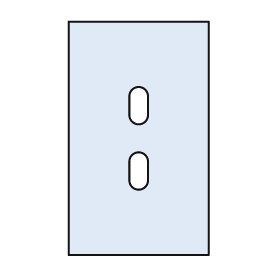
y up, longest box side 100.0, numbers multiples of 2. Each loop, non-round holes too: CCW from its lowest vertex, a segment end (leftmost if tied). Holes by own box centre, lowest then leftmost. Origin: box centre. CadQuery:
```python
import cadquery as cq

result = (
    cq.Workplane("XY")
    .moveTo(-30.0, -50.0)
    .lineTo(30.0, -50.0)
    .lineTo(30.0, 50.0)
    .lineTo(-30.0, 50.0)
    .close()
    .moveTo(-4.0, -18.0)
    .threePointArc((0.0, -22.0), (4.0, -18.0))
    .lineTo(4.0, -10.0)
    .threePointArc((0.0, -6.0), (-4.0, -10.0))
    .close()
    .moveTo(-4.0, 10.0)
    .threePointArc((0.0, 6.0), (4.0, 10.0))
    .lineTo(4.0, 18.0)
    .threePointArc((0.0, 22.0), (-4.0, 18.0))
    .close()
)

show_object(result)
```